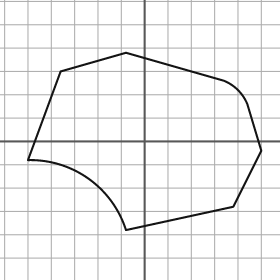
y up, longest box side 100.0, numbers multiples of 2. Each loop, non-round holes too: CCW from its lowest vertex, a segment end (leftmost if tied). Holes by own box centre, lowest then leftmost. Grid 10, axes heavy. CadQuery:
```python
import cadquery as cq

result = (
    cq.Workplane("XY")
    .moveTo(-8.0, -38.0)
    .lineTo(38.0, -28.0)
    .lineTo(50.0, -4.0)
    .lineTo(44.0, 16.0)
    .threePointArc((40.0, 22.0), (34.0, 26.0))
    .lineTo(-8.0, 38.0)
    .lineTo(-36.0, 30.0)
    .lineTo(-50.0, -8.0)
    .threePointArc((-24.0, -16.0), (-8.0, -38.0))
    .close()
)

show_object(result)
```